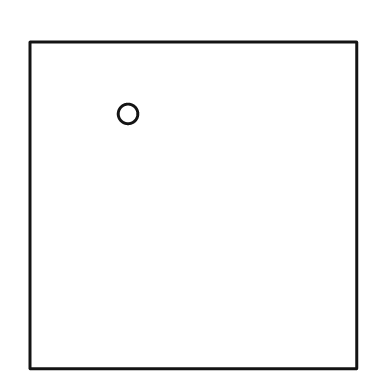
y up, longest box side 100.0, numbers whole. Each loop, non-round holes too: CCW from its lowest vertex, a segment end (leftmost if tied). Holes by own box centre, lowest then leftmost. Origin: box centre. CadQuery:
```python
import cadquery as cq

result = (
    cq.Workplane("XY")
    .moveTo(-50.0, -50.0)
    .lineTo(50.0, -50.0)
    .lineTo(50.0, 50.0)
    .lineTo(-50.0, 50.0)
    .close()
    .moveTo(-20.0, 28.0)
    .circle(3.0)
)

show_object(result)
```